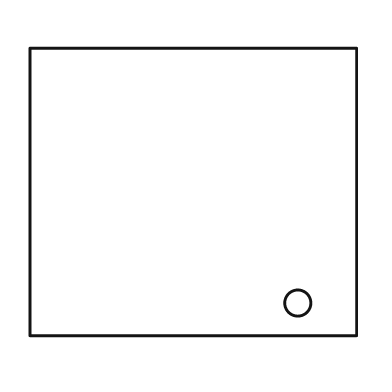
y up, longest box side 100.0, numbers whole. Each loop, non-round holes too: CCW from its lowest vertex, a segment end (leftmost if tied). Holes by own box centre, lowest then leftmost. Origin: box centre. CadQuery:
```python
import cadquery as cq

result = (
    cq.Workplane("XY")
    .moveTo(-50.0, -44.0)
    .lineTo(50.0, -44.0)
    .lineTo(50.0, 44.0)
    .lineTo(-50.0, 44.0)
    .close()
    .moveTo(32.0, -34.0)
    .circle(4.0)
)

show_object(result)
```